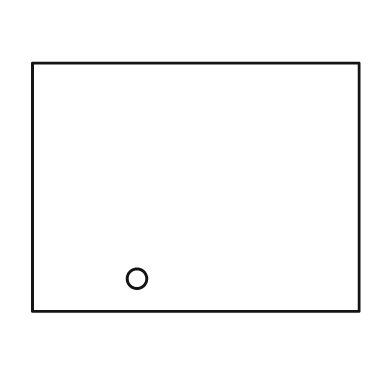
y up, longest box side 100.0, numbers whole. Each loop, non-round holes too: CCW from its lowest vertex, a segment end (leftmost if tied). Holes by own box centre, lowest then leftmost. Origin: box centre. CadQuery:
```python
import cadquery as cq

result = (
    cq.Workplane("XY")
    .moveTo(-50.0, -38.0)
    .lineTo(50.0, -38.0)
    .lineTo(50.0, 38.0)
    .lineTo(-50.0, 38.0)
    .close()
    .moveTo(-18.0, -28.0)
    .circle(3.0)
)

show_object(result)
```